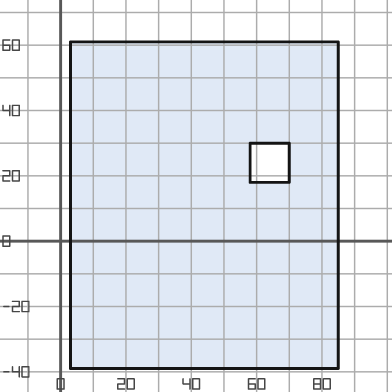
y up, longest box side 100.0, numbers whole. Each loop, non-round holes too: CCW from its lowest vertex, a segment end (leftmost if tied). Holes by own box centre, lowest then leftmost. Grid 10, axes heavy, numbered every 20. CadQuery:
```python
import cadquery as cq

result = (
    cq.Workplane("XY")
    .moveTo(3.0, -39.0)
    .lineTo(85.0, -39.0)
    .lineTo(85.0, 61.0)
    .lineTo(3.0, 61.0)
    .close()
    .moveTo(58.0, 18.0)
    .lineTo(70.0, 18.0)
    .lineTo(70.0, 30.0)
    .lineTo(58.0, 30.0)
    .close()
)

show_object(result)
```